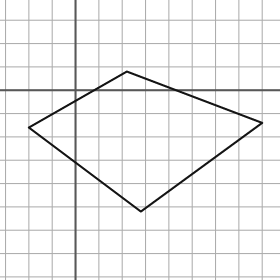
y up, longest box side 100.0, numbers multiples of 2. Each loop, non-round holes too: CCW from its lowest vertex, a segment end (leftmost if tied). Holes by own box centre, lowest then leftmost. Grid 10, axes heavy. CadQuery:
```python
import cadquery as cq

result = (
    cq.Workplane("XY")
    .moveTo(28.0, -52.0)
    .lineTo(80.0, -14.0)
    .lineTo(22.0, 8.0)
    .lineTo(-20.0, -16.0)
    .close()
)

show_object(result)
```